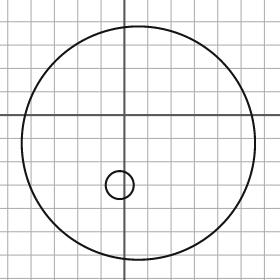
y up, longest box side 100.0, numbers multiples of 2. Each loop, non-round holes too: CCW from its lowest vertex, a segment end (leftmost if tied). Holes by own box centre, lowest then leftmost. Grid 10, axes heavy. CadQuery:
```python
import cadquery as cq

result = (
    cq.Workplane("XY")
    .moveTo(6.0, -12.0)
    .circle(50.0)
    .moveTo(-2.0, -30.0)
    .circle(6.0)
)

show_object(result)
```